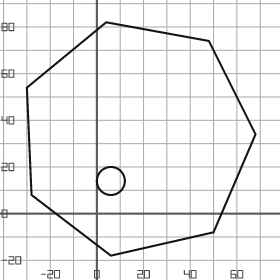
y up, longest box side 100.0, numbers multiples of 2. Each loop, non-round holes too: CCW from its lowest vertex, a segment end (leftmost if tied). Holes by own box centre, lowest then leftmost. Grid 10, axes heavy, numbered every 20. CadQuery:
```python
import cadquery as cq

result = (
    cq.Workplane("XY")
    .moveTo(6.0, -18.0)
    .lineTo(50.0, -8.0)
    .lineTo(68.0, 34.0)
    .lineTo(48.0, 74.0)
    .lineTo(4.0, 82.0)
    .lineTo(-30.0, 54.0)
    .lineTo(-28.0, 8.0)
    .close()
    .moveTo(6.0, 14.0)
    .circle(6.0)
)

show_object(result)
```